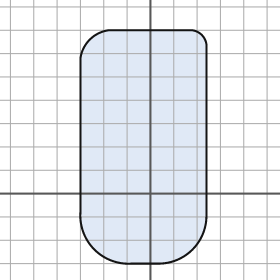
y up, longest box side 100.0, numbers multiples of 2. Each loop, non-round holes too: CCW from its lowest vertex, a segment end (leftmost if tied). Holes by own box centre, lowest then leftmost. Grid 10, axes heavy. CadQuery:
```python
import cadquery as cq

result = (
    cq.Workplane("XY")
    .moveTo(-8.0, -30.0)
    .lineTo(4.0, -30.0)
    .threePointArc((18.0, -24.0), (24.0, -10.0))
    .lineTo(24.0, 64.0)
    .threePointArc((22.0, 68.0), (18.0, 70.0))
    .lineTo(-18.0, 70.0)
    .threePointArc((-26.0, 66.0), (-30.0, 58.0))
    .lineTo(-30.0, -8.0)
    .threePointArc((-24.0, -24.0), (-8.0, -30.0))
    .close()
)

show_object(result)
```